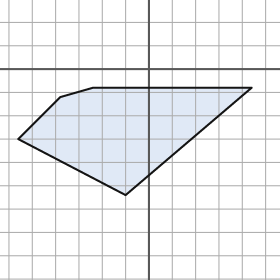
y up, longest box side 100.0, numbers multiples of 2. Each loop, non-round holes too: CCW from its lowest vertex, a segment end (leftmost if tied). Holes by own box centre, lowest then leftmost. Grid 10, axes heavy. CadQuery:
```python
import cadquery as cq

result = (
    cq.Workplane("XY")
    .moveTo(-10.0, -54.0)
    .lineTo(44.0, -8.0)
    .lineTo(-24.0, -8.0)
    .lineTo(-38.0, -12.0)
    .lineTo(-56.0, -30.0)
    .close()
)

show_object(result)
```